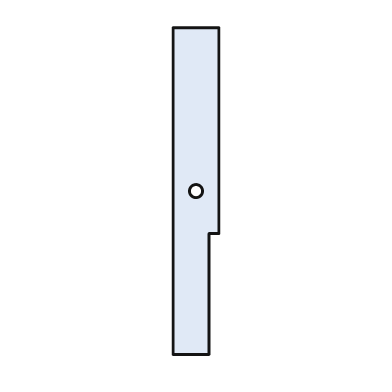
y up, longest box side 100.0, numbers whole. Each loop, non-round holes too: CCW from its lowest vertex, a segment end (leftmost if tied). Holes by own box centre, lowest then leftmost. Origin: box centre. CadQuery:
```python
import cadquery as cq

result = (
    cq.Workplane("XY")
    .moveTo(-7.0, -50.0)
    .lineTo(4.0, -50.0)
    .lineTo(4.0, -13.0)
    .lineTo(7.0, -13.0)
    .lineTo(7.0, 50.0)
    .lineTo(-7.0, 50.0)
    .close()
    .moveTo(0.0, 0.0)
    .circle(2.0)
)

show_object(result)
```